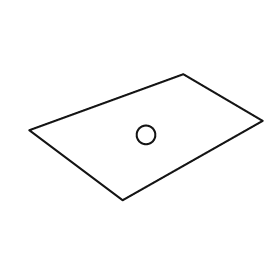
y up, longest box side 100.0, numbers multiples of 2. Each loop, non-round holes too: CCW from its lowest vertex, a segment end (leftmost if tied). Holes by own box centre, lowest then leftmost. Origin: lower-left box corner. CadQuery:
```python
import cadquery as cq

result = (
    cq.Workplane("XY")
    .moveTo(40.0, 0.0)
    .lineTo(100.0, 34.0)
    .lineTo(66.0, 54.0)
    .lineTo(0.0, 30.0)
    .close()
    .moveTo(50.0, 28.0)
    .circle(4.0)
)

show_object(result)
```